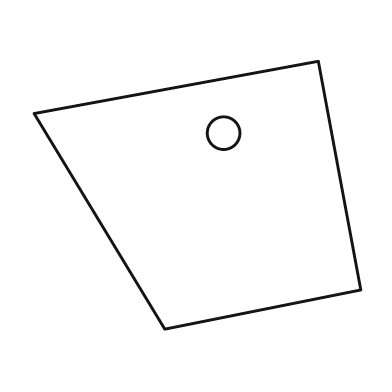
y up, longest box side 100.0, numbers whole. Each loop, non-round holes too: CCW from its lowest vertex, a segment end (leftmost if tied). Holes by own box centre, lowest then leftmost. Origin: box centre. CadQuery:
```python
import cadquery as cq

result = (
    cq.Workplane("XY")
    .moveTo(-10.0, -41.0)
    .lineTo(50.0, -29.0)
    .lineTo(37.0, 41.0)
    .lineTo(-50.0, 25.0)
    .close()
    .moveTo(8.0, 19.0)
    .circle(5.0)
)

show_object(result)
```